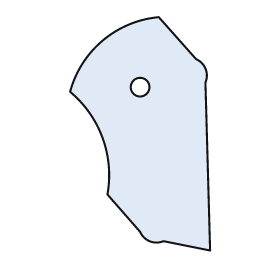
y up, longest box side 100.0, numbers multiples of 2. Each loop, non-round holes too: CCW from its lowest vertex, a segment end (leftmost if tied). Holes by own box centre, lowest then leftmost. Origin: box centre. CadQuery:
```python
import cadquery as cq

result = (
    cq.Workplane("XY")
    .moveTo(30.0, -50.0)
    .lineTo(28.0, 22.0)
    .threePointArc((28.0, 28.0), (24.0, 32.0))
    .lineTo(8.0, 50.0)
    .threePointArc((-16.0, 40.0), (-30.0, 18.0))
    .threePointArc((-16.0, -2.0), (-14.0, -26.0))
    .lineTo(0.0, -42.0)
    .threePointArc((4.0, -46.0), (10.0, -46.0))
    .close()
    .moveTo(0.0, 20.0)
    .circle(4.0)
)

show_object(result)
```